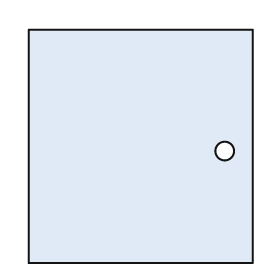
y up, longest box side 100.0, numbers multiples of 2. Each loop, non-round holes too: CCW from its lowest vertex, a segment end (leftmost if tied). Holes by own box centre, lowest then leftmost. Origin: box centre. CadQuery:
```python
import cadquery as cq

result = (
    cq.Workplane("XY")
    .moveTo(-48.0, -50.0)
    .lineTo(48.0, -50.0)
    .lineTo(48.0, 50.0)
    .lineTo(-48.0, 50.0)
    .close()
    .moveTo(36.0, -2.0)
    .circle(4.0)
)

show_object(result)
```